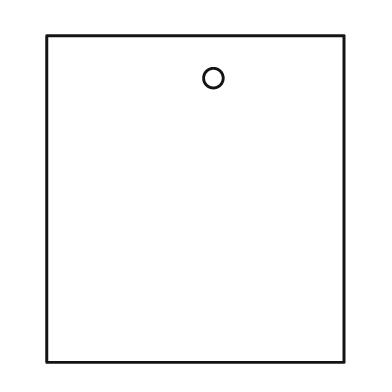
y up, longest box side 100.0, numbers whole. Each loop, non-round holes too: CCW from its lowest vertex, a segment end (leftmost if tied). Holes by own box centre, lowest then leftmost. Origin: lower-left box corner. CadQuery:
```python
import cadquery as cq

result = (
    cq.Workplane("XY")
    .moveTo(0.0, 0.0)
    .lineTo(91.0, 0.0)
    .lineTo(91.0, 100.0)
    .lineTo(0.0, 100.0)
    .close()
    .moveTo(51.0, 87.0)
    .circle(3.0)
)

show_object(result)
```